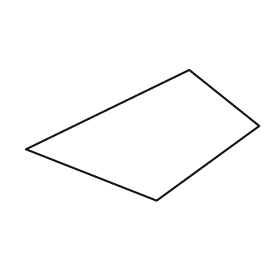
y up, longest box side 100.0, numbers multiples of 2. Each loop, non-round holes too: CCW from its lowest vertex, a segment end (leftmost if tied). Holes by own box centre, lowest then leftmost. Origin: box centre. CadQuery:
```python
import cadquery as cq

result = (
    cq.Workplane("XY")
    .moveTo(6.0, -28.0)
    .lineTo(50.0, 4.0)
    .lineTo(20.0, 28.0)
    .lineTo(-50.0, -6.0)
    .close()
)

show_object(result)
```